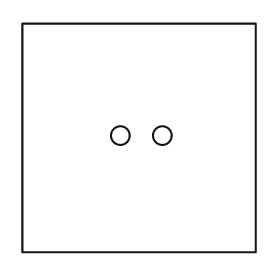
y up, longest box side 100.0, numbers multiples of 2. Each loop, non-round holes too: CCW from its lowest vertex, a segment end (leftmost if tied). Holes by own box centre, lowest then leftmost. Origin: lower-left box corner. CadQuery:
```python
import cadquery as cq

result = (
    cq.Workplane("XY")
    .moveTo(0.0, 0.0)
    .lineTo(100.0, 0.0)
    .lineTo(100.0, 98.0)
    .lineTo(0.0, 98.0)
    .close()
    .moveTo(42.0, 50.0)
    .circle(4.0)
    .moveTo(60.0, 50.0)
    .circle(4.0)
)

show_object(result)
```